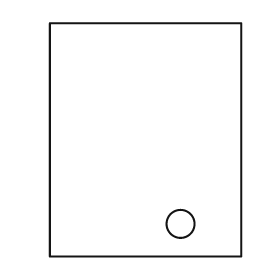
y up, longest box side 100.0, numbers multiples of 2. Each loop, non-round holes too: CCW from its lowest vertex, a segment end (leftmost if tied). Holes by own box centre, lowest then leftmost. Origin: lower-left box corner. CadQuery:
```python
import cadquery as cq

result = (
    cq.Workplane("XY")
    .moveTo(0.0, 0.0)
    .lineTo(82.0, 0.0)
    .lineTo(82.0, 100.0)
    .lineTo(0.0, 100.0)
    .close()
    .moveTo(56.0, 14.0)
    .circle(6.0)
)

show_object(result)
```